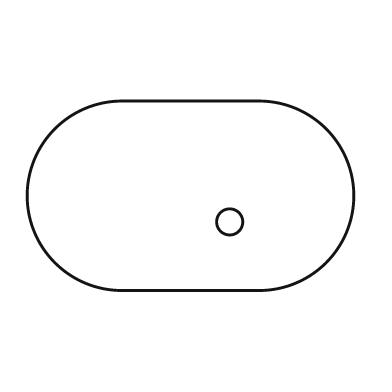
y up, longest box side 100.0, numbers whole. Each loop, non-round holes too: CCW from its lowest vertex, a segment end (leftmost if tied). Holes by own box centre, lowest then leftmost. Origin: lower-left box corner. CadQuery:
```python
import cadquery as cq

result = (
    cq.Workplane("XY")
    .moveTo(29.0, 0.0)
    .lineTo(71.0, 0.0)
    .threePointArc((100.0, 29.0), (71.0, 58.0))
    .lineTo(29.0, 58.0)
    .threePointArc((0.0, 29.0), (29.0, 0.0))
    .close()
    .moveTo(62.0, 21.0)
    .circle(4.0)
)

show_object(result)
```